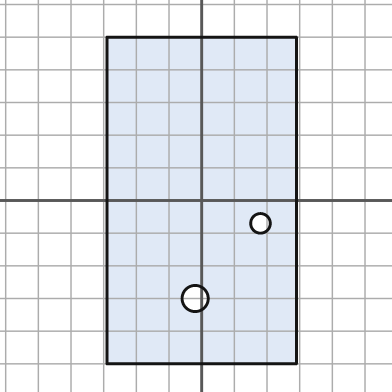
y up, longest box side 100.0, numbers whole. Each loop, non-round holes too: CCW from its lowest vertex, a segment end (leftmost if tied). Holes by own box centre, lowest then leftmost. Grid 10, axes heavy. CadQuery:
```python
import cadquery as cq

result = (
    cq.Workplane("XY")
    .moveTo(-29.0, -50.0)
    .lineTo(29.0, -50.0)
    .lineTo(29.0, 50.0)
    .lineTo(-29.0, 50.0)
    .close()
    .moveTo(-2.0, -30.0)
    .circle(4.0)
    .moveTo(18.0, -7.0)
    .circle(3.0)
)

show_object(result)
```